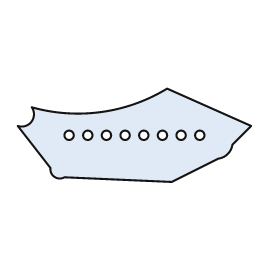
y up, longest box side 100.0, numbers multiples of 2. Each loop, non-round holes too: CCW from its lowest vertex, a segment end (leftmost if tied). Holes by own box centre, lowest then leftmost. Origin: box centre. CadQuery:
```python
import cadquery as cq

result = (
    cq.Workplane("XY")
    .moveTo(16.0, -20.0)
    .lineTo(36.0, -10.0)
    .threePointArc((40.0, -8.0), (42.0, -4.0))
    .lineTo(50.0, 4.0)
    .lineTo(14.0, 20.0)
    .threePointArc((-14.0, 10.0), (-44.0, 12.0))
    .threePointArc((-44.0, 6.0), (-50.0, 4.0))
    .lineTo(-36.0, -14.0)
    .threePointArc((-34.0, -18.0), (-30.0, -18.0))
    .close()
    .moveTo(-28.0, 0.0)
    .circle(2.0)
    .moveTo(-20.0, 0.0)
    .circle(2.0)
    .moveTo(-12.0, 0.0)
    .circle(2.0)
    .moveTo(-4.0, 0.0)
    .circle(2.0)
    .moveTo(4.0, 0.0)
    .circle(2.0)
    .moveTo(12.0, 0.0)
    .circle(2.0)
    .moveTo(20.0, 0.0)
    .circle(2.0)
    .moveTo(28.0, 0.0)
    .circle(2.0)
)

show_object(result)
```